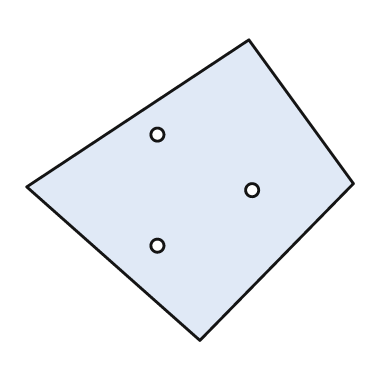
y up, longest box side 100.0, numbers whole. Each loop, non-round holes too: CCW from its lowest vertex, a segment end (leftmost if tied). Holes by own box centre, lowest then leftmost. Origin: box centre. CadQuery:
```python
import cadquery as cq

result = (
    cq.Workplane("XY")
    .moveTo(3.0, -46.0)
    .lineTo(50.0, 2.0)
    .lineTo(18.0, 46.0)
    .lineTo(-50.0, 1.0)
    .close()
    .moveTo(-10.0, -17.0)
    .circle(2.0)
    .moveTo(19.0, 0.0)
    .circle(2.0)
    .moveTo(-10.0, 17.0)
    .circle(2.0)
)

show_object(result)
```